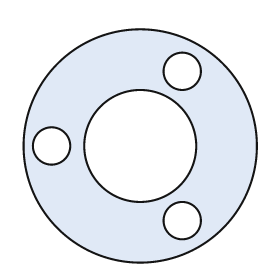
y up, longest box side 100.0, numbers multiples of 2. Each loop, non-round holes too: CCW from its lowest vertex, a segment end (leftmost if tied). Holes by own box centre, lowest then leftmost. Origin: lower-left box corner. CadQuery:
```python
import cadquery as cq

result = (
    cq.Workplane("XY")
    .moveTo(50.0, 50.0)
    .circle(50.0)
    .moveTo(68.0, 18.0)
    .circle(8.0)
    .moveTo(12.0, 50.0)
    .circle(8.0)
    .moveTo(50.0, 50.0)
    .circle(24.0)
    .moveTo(68.0, 82.0)
    .circle(8.0)
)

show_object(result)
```